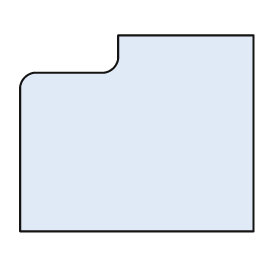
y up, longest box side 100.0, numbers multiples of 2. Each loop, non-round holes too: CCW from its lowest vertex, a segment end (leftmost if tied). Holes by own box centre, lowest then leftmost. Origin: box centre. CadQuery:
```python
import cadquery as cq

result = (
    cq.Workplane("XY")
    .moveTo(-50.0, -42.0)
    .lineTo(50.0, -42.0)
    .lineTo(50.0, 42.0)
    .lineTo(-8.0, 42.0)
    .lineTo(-8.0, 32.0)
    .threePointArc((-10.0, 28.0), (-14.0, 26.0))
    .lineTo(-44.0, 26.0)
    .threePointArc((-48.0, 24.0), (-50.0, 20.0))
    .close()
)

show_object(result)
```